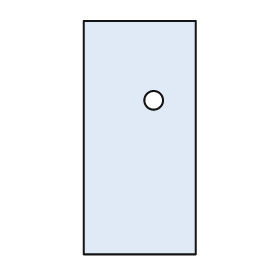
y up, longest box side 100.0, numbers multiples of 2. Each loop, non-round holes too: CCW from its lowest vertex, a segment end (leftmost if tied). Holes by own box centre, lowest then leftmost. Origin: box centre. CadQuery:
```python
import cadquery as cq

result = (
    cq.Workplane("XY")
    .moveTo(-24.0, -50.0)
    .lineTo(24.0, -50.0)
    .lineTo(24.0, 50.0)
    .lineTo(-24.0, 50.0)
    .close()
    .moveTo(6.0, 16.0)
    .circle(4.0)
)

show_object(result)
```